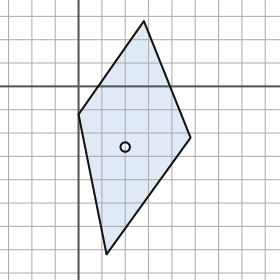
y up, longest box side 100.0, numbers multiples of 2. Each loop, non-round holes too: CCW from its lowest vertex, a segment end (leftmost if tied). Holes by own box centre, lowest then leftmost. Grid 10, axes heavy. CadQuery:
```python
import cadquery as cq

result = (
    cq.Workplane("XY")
    .moveTo(12.0, -72.0)
    .lineTo(48.0, -22.0)
    .lineTo(28.0, 28.0)
    .lineTo(0.0, -12.0)
    .close()
    .moveTo(20.0, -26.0)
    .circle(2.0)
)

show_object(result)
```